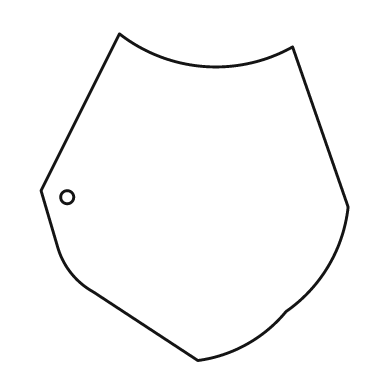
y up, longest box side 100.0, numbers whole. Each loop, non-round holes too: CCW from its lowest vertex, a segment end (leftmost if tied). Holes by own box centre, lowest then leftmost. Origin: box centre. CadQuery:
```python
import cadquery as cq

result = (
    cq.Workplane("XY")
    .moveTo(1.0, -50.0)
    .threePointArc((16.0, -45.0), (28.0, -35.0))
    .threePointArc((41.0, -21.0), (47.0, -3.0))
    .lineTo(30.0, 46.0)
    .threePointArc((3.0, 40.0), (-23.0, 50.0))
    .lineTo(-47.0, 2.0)
    .lineTo(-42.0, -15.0)
    .threePointArc((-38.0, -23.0), (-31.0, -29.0))
    .close()
    .moveTo(-39.0, 0.0)
    .circle(2.0)
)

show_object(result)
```